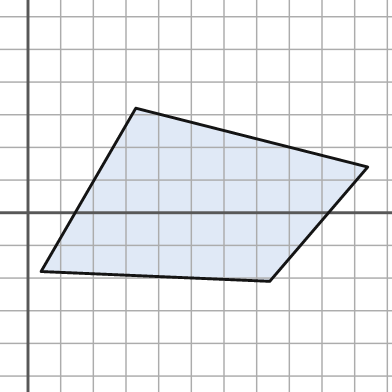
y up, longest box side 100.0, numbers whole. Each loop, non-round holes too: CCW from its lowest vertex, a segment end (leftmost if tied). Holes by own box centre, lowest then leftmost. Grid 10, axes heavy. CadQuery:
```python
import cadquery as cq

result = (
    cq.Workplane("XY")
    .moveTo(74.0, -21.0)
    .lineTo(104.0, 14.0)
    .lineTo(33.0, 32.0)
    .lineTo(4.0, -18.0)
    .close()
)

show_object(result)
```